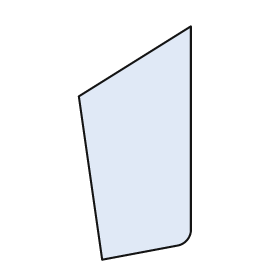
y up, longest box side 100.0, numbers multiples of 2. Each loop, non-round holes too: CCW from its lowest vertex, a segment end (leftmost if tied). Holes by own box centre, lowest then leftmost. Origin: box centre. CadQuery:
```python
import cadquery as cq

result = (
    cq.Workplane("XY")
    .moveTo(-14.0, -50.0)
    .lineTo(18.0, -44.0)
    .threePointArc((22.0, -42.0), (24.0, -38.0))
    .lineTo(24.0, 50.0)
    .lineTo(-24.0, 20.0)
    .close()
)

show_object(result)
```